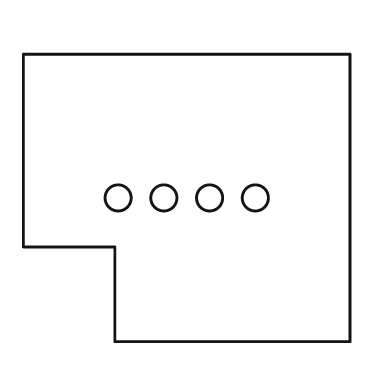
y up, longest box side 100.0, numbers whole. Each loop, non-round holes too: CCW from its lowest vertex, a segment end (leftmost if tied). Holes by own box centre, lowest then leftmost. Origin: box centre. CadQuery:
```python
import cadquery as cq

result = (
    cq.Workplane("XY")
    .moveTo(-22.0, -44.0)
    .lineTo(50.0, -44.0)
    .lineTo(50.0, 44.0)
    .lineTo(-50.0, 44.0)
    .lineTo(-50.0, -15.0)
    .lineTo(-22.0, -15.0)
    .close()
    .moveTo(-21.0, 0.0)
    .circle(4.0)
    .moveTo(-7.0, 0.0)
    .circle(4.0)
    .moveTo(7.0, 0.0)
    .circle(4.0)
    .moveTo(21.0, 0.0)
    .circle(4.0)
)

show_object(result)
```